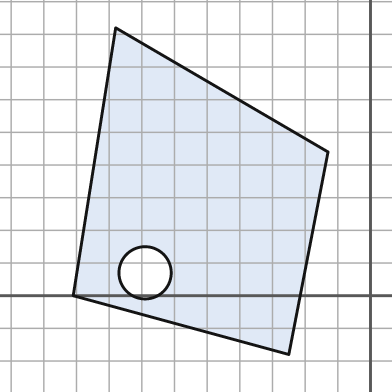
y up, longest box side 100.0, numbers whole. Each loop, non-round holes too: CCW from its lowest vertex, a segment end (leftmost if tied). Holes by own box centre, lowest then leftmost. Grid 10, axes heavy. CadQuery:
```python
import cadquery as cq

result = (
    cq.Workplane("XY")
    .moveTo(-25.0, -18.0)
    .lineTo(-13.0, 44.0)
    .lineTo(-78.0, 82.0)
    .lineTo(-91.0, 0.0)
    .close()
    .moveTo(-69.0, 7.0)
    .circle(8.0)
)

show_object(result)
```